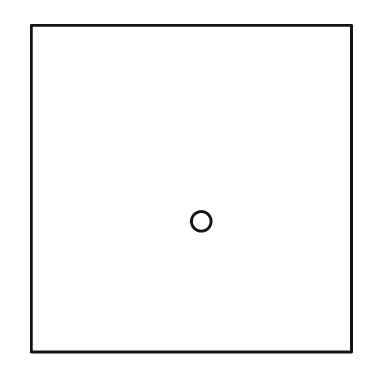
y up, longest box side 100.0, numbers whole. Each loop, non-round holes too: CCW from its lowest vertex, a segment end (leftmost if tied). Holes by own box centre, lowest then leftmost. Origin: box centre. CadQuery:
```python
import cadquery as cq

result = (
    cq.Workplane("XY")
    .moveTo(-49.0, -50.0)
    .lineTo(49.0, -50.0)
    .lineTo(49.0, 50.0)
    .lineTo(-49.0, 50.0)
    .close()
    .moveTo(3.0, -10.0)
    .circle(3.0)
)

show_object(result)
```